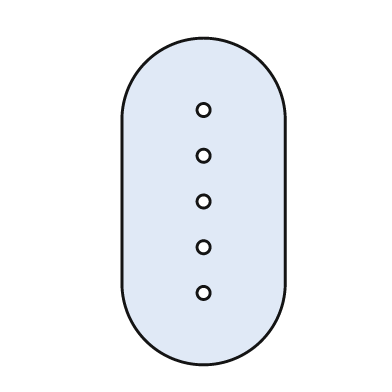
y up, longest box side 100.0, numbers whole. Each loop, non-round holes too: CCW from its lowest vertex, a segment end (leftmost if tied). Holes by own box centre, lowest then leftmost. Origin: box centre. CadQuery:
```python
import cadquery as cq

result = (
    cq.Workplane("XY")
    .moveTo(-25.0, -25.0)
    .threePointArc((0.0, -50.0), (25.0, -25.0))
    .lineTo(25.0, 25.0)
    .threePointArc((0.0, 50.0), (-25.0, 25.0))
    .close()
    .moveTo(0.0, -28.0)
    .circle(2.0)
    .moveTo(0.0, -14.0)
    .circle(2.0)
    .moveTo(0.0, 0.0)
    .circle(2.0)
    .moveTo(0.0, 14.0)
    .circle(2.0)
    .moveTo(0.0, 28.0)
    .circle(2.0)
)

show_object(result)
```